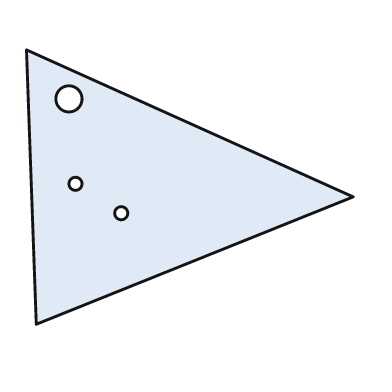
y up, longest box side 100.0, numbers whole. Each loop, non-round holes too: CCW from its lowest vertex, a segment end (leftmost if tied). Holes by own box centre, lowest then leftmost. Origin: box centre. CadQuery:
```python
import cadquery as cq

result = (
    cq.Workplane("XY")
    .moveTo(-47.0, -42.0)
    .lineTo(50.0, -3.0)
    .lineTo(-50.0, 42.0)
    .close()
    .moveTo(-21.0, -8.0)
    .circle(2.0)
    .moveTo(-35.0, 1.0)
    .circle(2.0)
    .moveTo(-37.0, 27.0)
    .circle(4.0)
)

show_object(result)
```